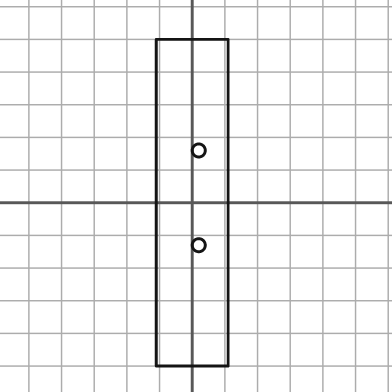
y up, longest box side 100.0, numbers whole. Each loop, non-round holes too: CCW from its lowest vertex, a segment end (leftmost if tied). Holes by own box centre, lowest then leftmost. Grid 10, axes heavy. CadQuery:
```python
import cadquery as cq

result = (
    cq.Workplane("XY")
    .moveTo(-11.0, -50.0)
    .lineTo(11.0, -50.0)
    .lineTo(11.0, 50.0)
    .lineTo(-11.0, 50.0)
    .close()
    .moveTo(2.0, -13.0)
    .circle(2.0)
    .moveTo(2.0, 16.0)
    .circle(2.0)
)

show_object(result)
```